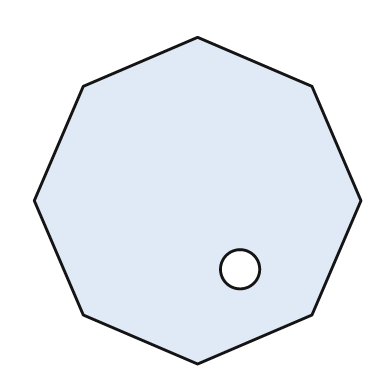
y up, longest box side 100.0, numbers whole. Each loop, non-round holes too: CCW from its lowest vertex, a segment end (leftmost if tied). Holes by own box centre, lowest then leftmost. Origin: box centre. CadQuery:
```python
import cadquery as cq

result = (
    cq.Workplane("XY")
    .moveTo(0.0, -50.0)
    .lineTo(35.0, -35.0)
    .lineTo(50.0, 0.0)
    .lineTo(35.0, 35.0)
    .lineTo(0.0, 50.0)
    .lineTo(-35.0, 35.0)
    .lineTo(-50.0, 0.0)
    .lineTo(-35.0, -35.0)
    .close()
    .moveTo(13.0, -21.0)
    .circle(6.0)
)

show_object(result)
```